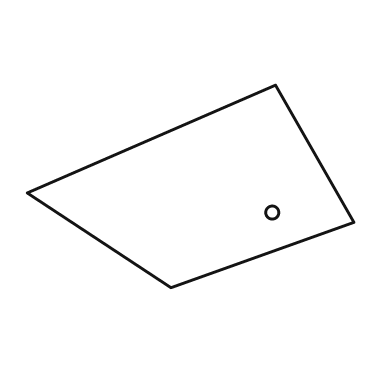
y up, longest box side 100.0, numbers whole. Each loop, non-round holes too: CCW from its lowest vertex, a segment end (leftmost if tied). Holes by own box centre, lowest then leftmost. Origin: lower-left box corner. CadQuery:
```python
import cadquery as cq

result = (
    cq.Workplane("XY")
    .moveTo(44.0, 0.0)
    .lineTo(100.0, 20.0)
    .lineTo(76.0, 62.0)
    .lineTo(0.0, 29.0)
    .close()
    .moveTo(75.0, 23.0)
    .circle(2.0)
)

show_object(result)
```